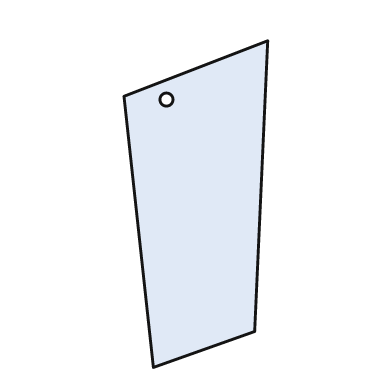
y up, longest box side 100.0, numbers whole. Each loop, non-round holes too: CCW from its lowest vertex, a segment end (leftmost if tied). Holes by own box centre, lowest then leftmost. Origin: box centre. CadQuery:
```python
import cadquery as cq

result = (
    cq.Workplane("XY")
    .moveTo(-13.0, -50.0)
    .lineTo(18.0, -39.0)
    .lineTo(22.0, 50.0)
    .lineTo(-22.0, 33.0)
    .close()
    .moveTo(-9.0, 32.0)
    .circle(2.0)
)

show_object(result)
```